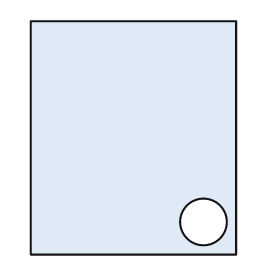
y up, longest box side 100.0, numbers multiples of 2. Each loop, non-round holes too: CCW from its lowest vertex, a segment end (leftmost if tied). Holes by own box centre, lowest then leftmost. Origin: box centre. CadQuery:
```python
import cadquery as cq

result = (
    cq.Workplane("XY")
    .moveTo(-44.0, -50.0)
    .lineTo(44.0, -50.0)
    .lineTo(44.0, 50.0)
    .lineTo(-44.0, 50.0)
    .close()
    .moveTo(30.0, -36.0)
    .circle(10.0)
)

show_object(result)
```